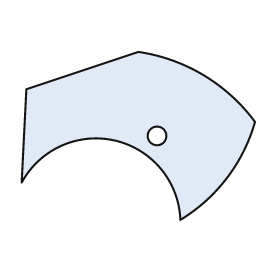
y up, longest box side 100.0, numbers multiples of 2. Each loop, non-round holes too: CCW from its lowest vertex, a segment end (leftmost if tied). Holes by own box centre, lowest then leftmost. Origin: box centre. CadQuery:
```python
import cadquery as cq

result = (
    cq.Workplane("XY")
    .moveTo(18.0, -36.0)
    .threePointArc((38.0, -18.0), (50.0, 6.0))
    .threePointArc((28.0, 26.0), (0.0, 36.0))
    .lineTo(-48.0, 20.0)
    .lineTo(-50.0, -20.0)
    .threePointArc((-10.0, -2.0), (18.0, -36.0))
    .close()
    .moveTo(8.0, 0.0)
    .circle(4.0)
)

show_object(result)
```